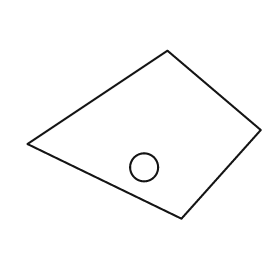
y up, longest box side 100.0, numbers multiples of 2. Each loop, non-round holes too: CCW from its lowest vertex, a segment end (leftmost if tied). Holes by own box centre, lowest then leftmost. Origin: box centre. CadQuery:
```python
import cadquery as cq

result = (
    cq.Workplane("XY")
    .moveTo(16.0, -36.0)
    .lineTo(50.0, 2.0)
    .lineTo(10.0, 36.0)
    .lineTo(-50.0, -4.0)
    .close()
    .moveTo(0.0, -14.0)
    .circle(6.0)
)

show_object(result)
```